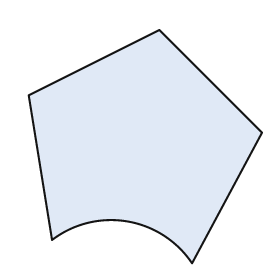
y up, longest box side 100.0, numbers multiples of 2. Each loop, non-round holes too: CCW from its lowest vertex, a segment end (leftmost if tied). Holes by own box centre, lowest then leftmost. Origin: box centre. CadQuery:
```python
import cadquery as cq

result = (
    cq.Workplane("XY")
    .moveTo(20.0, -50.0)
    .lineTo(50.0, 6.0)
    .lineTo(6.0, 50.0)
    .lineTo(-50.0, 22.0)
    .lineTo(-40.0, -40.0)
    .threePointArc((-8.0, -32.0), (20.0, -50.0))
    .close()
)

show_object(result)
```